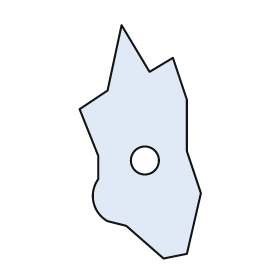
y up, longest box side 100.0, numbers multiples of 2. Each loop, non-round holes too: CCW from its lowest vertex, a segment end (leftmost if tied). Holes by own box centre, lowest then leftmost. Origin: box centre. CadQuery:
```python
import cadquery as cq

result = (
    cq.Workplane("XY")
    .moveTo(10.0, -50.0)
    .lineTo(20.0, -48.0)
    .lineTo(26.0, -22.0)
    .lineTo(20.0, -4.0)
    .lineTo(20.0, 18.0)
    .lineTo(14.0, 36.0)
    .lineTo(4.0, 30.0)
    .lineTo(-8.0, 50.0)
    .lineTo(-14.0, 22.0)
    .lineTo(-26.0, 14.0)
    .lineTo(-18.0, -6.0)
    .lineTo(-18.0, -16.0)
    .threePointArc((-20.0, -26.0), (-14.0, -34.0))
    .lineTo(-6.0, -36.0)
    .close()
    .moveTo(2.0, -8.0)
    .circle(6.0)
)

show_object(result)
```